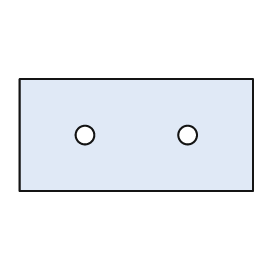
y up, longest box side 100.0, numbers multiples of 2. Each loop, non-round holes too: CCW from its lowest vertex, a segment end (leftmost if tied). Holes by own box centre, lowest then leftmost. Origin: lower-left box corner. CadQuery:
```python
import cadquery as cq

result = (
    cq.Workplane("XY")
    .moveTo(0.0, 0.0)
    .lineTo(100.0, 0.0)
    .lineTo(100.0, 48.0)
    .lineTo(0.0, 48.0)
    .close()
    .moveTo(28.0, 24.0)
    .circle(4.0)
    .moveTo(72.0, 24.0)
    .circle(4.0)
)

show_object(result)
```